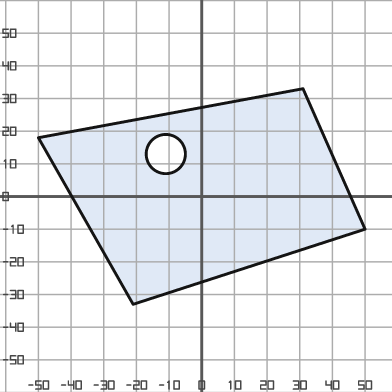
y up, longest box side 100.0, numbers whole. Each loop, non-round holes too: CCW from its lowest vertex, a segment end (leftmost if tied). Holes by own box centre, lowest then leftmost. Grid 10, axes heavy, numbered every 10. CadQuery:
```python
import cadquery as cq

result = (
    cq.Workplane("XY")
    .moveTo(-21.0, -33.0)
    .lineTo(50.0, -10.0)
    .lineTo(31.0, 33.0)
    .lineTo(-50.0, 18.0)
    .close()
    .moveTo(-11.0, 13.0)
    .circle(6.0)
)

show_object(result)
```